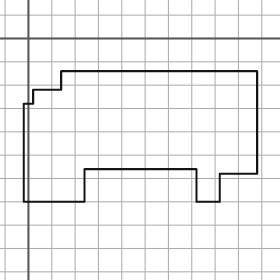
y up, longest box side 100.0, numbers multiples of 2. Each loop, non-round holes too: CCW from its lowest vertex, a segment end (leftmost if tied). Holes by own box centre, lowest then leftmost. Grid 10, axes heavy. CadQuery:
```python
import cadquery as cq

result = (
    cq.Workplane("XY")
    .moveTo(-2.0, -70.0)
    .lineTo(24.0, -70.0)
    .lineTo(24.0, -56.0)
    .lineTo(72.0, -56.0)
    .lineTo(72.0, -70.0)
    .lineTo(82.0, -70.0)
    .lineTo(82.0, -58.0)
    .lineTo(98.0, -58.0)
    .lineTo(98.0, -14.0)
    .lineTo(14.0, -14.0)
    .lineTo(14.0, -22.0)
    .lineTo(2.0, -22.0)
    .lineTo(2.0, -28.0)
    .lineTo(-2.0, -28.0)
    .close()
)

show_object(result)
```